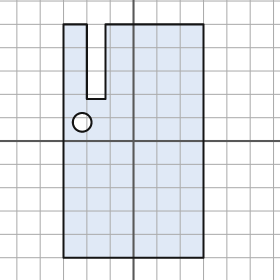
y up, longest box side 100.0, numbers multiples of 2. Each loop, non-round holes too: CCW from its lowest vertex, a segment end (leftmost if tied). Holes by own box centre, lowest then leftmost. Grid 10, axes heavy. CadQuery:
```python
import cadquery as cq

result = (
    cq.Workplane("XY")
    .moveTo(-30.0, -50.0)
    .lineTo(30.0, -50.0)
    .lineTo(30.0, 50.0)
    .lineTo(-12.0, 50.0)
    .lineTo(-12.0, 18.0)
    .lineTo(-20.0, 18.0)
    .lineTo(-20.0, 50.0)
    .lineTo(-30.0, 50.0)
    .close()
    .moveTo(-22.0, 8.0)
    .circle(4.0)
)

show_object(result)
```